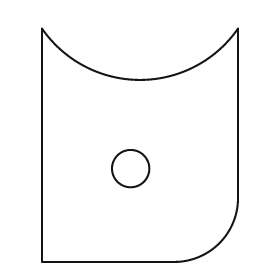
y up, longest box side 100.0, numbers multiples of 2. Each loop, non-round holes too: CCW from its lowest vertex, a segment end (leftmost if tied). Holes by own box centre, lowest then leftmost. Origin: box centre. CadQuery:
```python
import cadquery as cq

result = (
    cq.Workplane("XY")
    .moveTo(-42.0, -50.0)
    .lineTo(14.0, -50.0)
    .threePointArc((34.0, -42.0), (42.0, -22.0))
    .lineTo(42.0, 50.0)
    .threePointArc((0.0, 28.0), (-42.0, 50.0))
    .close()
    .moveTo(-4.0, -10.0)
    .circle(8.0)
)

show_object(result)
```